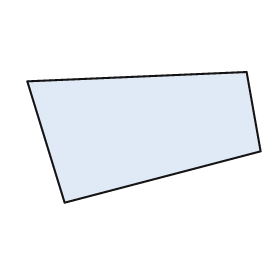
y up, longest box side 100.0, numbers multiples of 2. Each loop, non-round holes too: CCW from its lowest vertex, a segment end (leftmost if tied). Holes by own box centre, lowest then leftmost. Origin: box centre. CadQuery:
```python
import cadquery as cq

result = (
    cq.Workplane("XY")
    .moveTo(-34.0, -28.0)
    .lineTo(50.0, -6.0)
    .lineTo(44.0, 28.0)
    .lineTo(-50.0, 24.0)
    .close()
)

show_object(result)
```